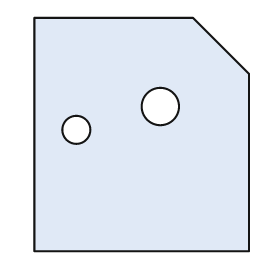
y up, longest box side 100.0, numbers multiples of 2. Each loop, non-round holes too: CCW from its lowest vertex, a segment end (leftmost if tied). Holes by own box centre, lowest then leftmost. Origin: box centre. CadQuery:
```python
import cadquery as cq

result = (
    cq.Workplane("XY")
    .moveTo(-46.0, -50.0)
    .lineTo(46.0, -50.0)
    .lineTo(46.0, 26.0)
    .lineTo(22.0, 50.0)
    .lineTo(-46.0, 50.0)
    .close()
    .moveTo(-28.0, 2.0)
    .circle(6.0)
    .moveTo(8.0, 12.0)
    .circle(8.0)
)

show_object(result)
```